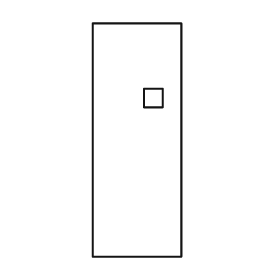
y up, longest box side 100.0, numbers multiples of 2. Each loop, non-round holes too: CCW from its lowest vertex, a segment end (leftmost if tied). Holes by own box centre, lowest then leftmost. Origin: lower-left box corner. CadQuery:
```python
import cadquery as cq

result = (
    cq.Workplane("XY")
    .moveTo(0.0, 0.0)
    .lineTo(38.0, 0.0)
    .lineTo(38.0, 100.0)
    .lineTo(0.0, 100.0)
    .close()
    .moveTo(22.0, 64.0)
    .lineTo(30.0, 64.0)
    .lineTo(30.0, 72.0)
    .lineTo(22.0, 72.0)
    .close()
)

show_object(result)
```